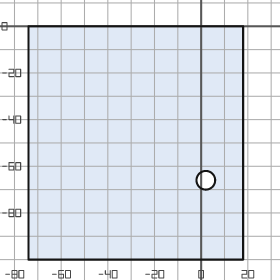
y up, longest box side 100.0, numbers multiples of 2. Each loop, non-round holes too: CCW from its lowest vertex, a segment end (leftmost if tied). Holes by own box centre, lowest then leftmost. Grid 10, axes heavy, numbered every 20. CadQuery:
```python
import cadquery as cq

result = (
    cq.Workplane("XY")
    .moveTo(-74.0, -100.0)
    .lineTo(18.0, -100.0)
    .lineTo(18.0, 0.0)
    .lineTo(-74.0, 0.0)
    .close()
    .moveTo(2.0, -66.0)
    .circle(4.0)
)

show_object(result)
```